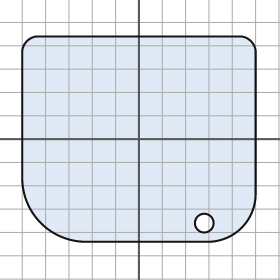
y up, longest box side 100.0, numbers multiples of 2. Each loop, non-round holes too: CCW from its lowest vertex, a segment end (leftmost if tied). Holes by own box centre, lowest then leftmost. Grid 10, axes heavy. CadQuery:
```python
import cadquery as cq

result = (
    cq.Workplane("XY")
    .moveTo(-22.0, -44.0)
    .lineTo(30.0, -44.0)
    .threePointArc((44.0, -38.0), (50.0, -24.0))
    .lineTo(50.0, 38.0)
    .threePointArc((48.0, 42.0), (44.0, 44.0))
    .lineTo(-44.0, 44.0)
    .threePointArc((-48.0, 42.0), (-50.0, 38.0))
    .lineTo(-50.0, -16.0)
    .threePointArc((-42.0, -36.0), (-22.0, -44.0))
    .close()
    .moveTo(28.0, -36.0)
    .circle(4.0)
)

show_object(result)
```